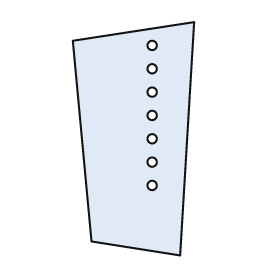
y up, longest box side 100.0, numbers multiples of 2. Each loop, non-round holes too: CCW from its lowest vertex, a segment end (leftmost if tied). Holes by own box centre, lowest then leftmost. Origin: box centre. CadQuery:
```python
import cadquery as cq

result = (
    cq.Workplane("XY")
    .moveTo(20.0, -50.0)
    .lineTo(26.0, 50.0)
    .lineTo(-26.0, 42.0)
    .lineTo(-18.0, -44.0)
    .close()
    .moveTo(8.0, -20.0)
    .circle(2.0)
    .moveTo(8.0, -10.0)
    .circle(2.0)
    .moveTo(8.0, 0.0)
    .circle(2.0)
    .moveTo(8.0, 10.0)
    .circle(2.0)
    .moveTo(8.0, 20.0)
    .circle(2.0)
    .moveTo(8.0, 30.0)
    .circle(2.0)
    .moveTo(8.0, 40.0)
    .circle(2.0)
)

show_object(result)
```